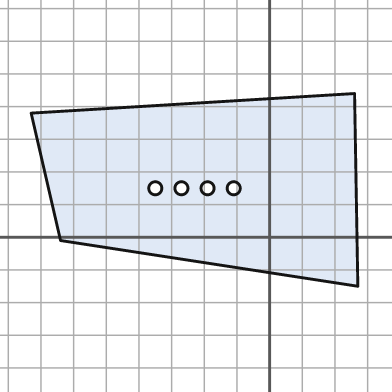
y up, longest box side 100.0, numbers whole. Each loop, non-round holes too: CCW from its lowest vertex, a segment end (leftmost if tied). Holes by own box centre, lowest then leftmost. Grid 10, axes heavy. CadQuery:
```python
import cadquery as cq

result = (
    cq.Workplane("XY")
    .moveTo(27.0, -15.0)
    .lineTo(26.0, 44.0)
    .lineTo(-73.0, 38.0)
    .lineTo(-64.0, -1.0)
    .close()
    .moveTo(-35.0, 15.0)
    .circle(2.0)
    .moveTo(-27.0, 15.0)
    .circle(2.0)
    .moveTo(-19.0, 15.0)
    .circle(2.0)
    .moveTo(-11.0, 15.0)
    .circle(2.0)
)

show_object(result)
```